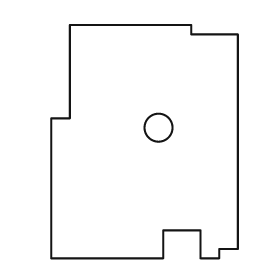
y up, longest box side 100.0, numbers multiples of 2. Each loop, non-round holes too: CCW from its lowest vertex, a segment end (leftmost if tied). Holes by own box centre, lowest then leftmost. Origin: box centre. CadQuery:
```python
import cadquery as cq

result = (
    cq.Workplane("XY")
    .moveTo(-40.0, -50.0)
    .lineTo(8.0, -50.0)
    .lineTo(8.0, -38.0)
    .lineTo(24.0, -38.0)
    .lineTo(24.0, -50.0)
    .lineTo(32.0, -50.0)
    .lineTo(32.0, -46.0)
    .lineTo(40.0, -46.0)
    .lineTo(40.0, 46.0)
    .lineTo(20.0, 46.0)
    .lineTo(20.0, 50.0)
    .lineTo(-32.0, 50.0)
    .lineTo(-32.0, 10.0)
    .lineTo(-40.0, 10.0)
    .close()
    .moveTo(6.0, 6.0)
    .circle(6.0)
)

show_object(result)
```